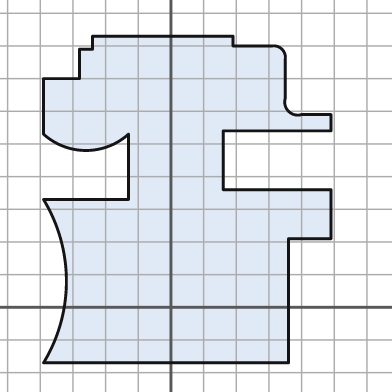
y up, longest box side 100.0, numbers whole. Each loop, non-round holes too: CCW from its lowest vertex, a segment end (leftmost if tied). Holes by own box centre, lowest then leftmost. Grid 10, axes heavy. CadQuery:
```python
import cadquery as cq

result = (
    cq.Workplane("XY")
    .moveTo(-39.0, -17.0)
    .lineTo(36.0, -17.0)
    .lineTo(36.0, 21.0)
    .lineTo(49.0, 21.0)
    .lineTo(49.0, 36.0)
    .lineTo(16.0, 36.0)
    .lineTo(16.0, 54.0)
    .lineTo(49.0, 54.0)
    .lineTo(49.0, 59.0)
    .lineTo(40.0, 59.0)
    .threePointArc((36.0, 60.0), (35.0, 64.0))
    .lineTo(35.0, 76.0)
    .threePointArc((34.0, 79.0), (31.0, 80.0))
    .lineTo(19.0, 80.0)
    .lineTo(19.0, 83.0)
    .lineTo(-24.0, 83.0)
    .lineTo(-24.0, 79.0)
    .lineTo(-28.0, 79.0)
    .lineTo(-28.0, 70.0)
    .lineTo(-39.0, 70.0)
    .lineTo(-39.0, 53.0)
    .threePointArc((-26.0, 48.0), (-13.0, 53.0))
    .lineTo(-13.0, 33.0)
    .lineTo(-39.0, 33.0)
    .threePointArc((-32.0, 8.0), (-39.0, -17.0))
    .close()
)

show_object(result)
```